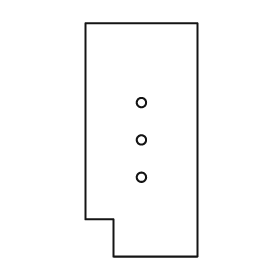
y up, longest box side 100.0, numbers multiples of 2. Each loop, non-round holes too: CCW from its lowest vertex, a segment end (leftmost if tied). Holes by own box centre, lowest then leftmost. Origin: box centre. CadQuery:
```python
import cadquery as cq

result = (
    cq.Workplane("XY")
    .moveTo(-12.0, -50.0)
    .lineTo(24.0, -50.0)
    .lineTo(24.0, 50.0)
    .lineTo(-24.0, 50.0)
    .lineTo(-24.0, -34.0)
    .lineTo(-12.0, -34.0)
    .close()
    .moveTo(0.0, -16.0)
    .circle(2.0)
    .moveTo(0.0, 0.0)
    .circle(2.0)
    .moveTo(0.0, 16.0)
    .circle(2.0)
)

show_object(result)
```